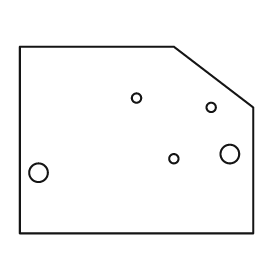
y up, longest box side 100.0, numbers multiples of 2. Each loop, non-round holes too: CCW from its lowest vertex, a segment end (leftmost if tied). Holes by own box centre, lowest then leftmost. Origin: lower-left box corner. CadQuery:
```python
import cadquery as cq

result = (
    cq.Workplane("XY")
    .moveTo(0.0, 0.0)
    .lineTo(100.0, 0.0)
    .lineTo(100.0, 54.0)
    .lineTo(66.0, 80.0)
    .lineTo(0.0, 80.0)
    .close()
    .moveTo(8.0, 26.0)
    .circle(4.0)
    .moveTo(66.0, 32.0)
    .circle(2.0)
    .moveTo(90.0, 34.0)
    .circle(4.0)
    .moveTo(82.0, 54.0)
    .circle(2.0)
    .moveTo(50.0, 58.0)
    .circle(2.0)
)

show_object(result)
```